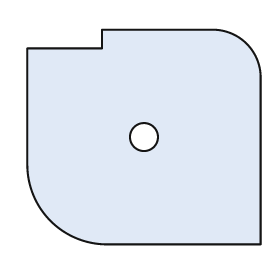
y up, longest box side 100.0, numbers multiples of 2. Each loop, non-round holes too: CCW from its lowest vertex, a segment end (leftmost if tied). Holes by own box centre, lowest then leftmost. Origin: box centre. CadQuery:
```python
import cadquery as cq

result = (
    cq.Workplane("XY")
    .moveTo(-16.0, -46.0)
    .lineTo(50.0, -46.0)
    .lineTo(50.0, 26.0)
    .threePointArc((44.0, 40.0), (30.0, 46.0))
    .lineTo(-18.0, 46.0)
    .lineTo(-18.0, 38.0)
    .lineTo(-50.0, 38.0)
    .lineTo(-50.0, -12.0)
    .threePointArc((-40.0, -36.0), (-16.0, -46.0))
    .close()
    .moveTo(0.0, 0.0)
    .circle(6.0)
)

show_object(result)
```